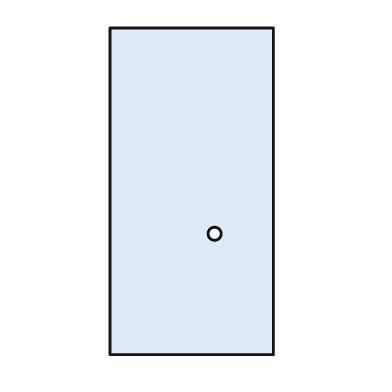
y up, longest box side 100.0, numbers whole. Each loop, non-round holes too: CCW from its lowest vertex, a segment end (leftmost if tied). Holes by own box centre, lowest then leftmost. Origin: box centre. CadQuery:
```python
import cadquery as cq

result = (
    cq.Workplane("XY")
    .moveTo(-25.0, -50.0)
    .lineTo(25.0, -50.0)
    .lineTo(25.0, 50.0)
    .lineTo(-25.0, 50.0)
    .close()
    .moveTo(7.0, -13.0)
    .circle(2.0)
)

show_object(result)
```